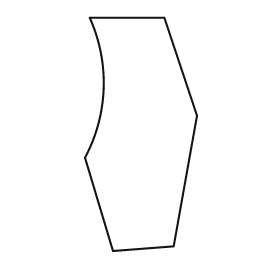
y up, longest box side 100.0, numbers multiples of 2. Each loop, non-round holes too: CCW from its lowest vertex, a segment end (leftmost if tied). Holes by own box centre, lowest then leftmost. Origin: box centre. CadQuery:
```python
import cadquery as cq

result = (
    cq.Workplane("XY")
    .moveTo(-12.0, -50.0)
    .lineTo(14.0, -48.0)
    .lineTo(24.0, 8.0)
    .lineTo(10.0, 50.0)
    .lineTo(-22.0, 50.0)
    .threePointArc((-16.0, 20.0), (-24.0, -10.0))
    .close()
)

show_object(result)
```